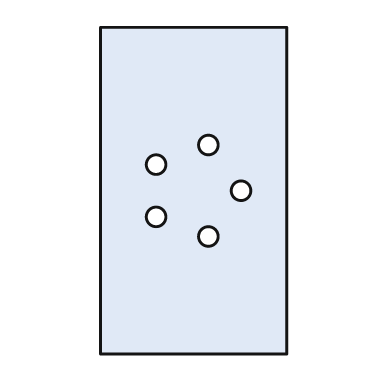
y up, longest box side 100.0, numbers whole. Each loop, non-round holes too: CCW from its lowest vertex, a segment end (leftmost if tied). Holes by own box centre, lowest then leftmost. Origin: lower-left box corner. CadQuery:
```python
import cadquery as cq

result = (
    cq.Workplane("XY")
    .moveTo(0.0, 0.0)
    .lineTo(57.0, 0.0)
    .lineTo(57.0, 100.0)
    .lineTo(0.0, 100.0)
    .close()
    .moveTo(33.0, 36.0)
    .circle(3.0)
    .moveTo(17.0, 42.0)
    .circle(3.0)
    .moveTo(43.0, 50.0)
    .circle(3.0)
    .moveTo(17.0, 58.0)
    .circle(3.0)
    .moveTo(33.0, 64.0)
    .circle(3.0)
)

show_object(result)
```